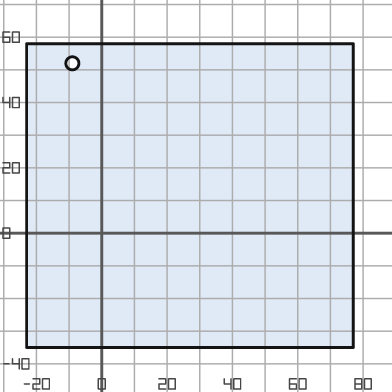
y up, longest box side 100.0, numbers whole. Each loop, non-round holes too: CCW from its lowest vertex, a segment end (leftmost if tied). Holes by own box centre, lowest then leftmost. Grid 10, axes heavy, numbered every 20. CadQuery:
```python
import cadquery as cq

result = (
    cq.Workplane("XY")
    .moveTo(-23.0, -35.0)
    .lineTo(77.0, -35.0)
    .lineTo(77.0, 58.0)
    .lineTo(-23.0, 58.0)
    .close()
    .moveTo(-9.0, 52.0)
    .circle(2.0)
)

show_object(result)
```